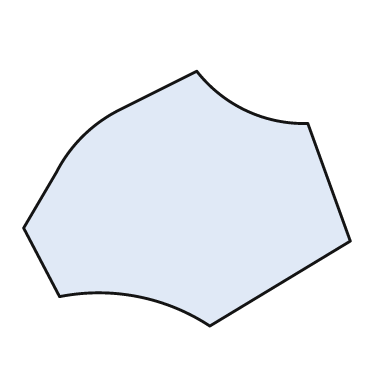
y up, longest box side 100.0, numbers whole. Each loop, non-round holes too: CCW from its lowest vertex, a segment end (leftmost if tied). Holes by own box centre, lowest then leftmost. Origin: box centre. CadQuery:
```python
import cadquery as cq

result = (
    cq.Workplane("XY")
    .moveTo(7.0, -39.0)
    .lineTo(50.0, -13.0)
    .lineTo(37.0, 23.0)
    .threePointArc((18.0, 27.0), (3.0, 39.0))
    .lineTo(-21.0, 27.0)
    .threePointArc((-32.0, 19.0), (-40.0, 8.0))
    .lineTo(-50.0, -9.0)
    .lineTo(-39.0, -30.0)
    .threePointArc((-15.0, -30.0), (7.0, -39.0))
    .close()
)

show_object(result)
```